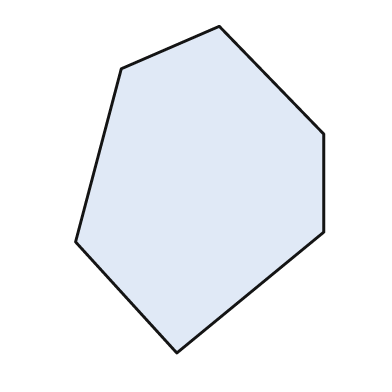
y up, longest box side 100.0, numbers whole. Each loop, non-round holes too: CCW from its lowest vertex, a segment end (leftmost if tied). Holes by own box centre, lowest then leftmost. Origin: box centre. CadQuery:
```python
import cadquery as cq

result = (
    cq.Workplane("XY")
    .moveTo(-7.0, -50.0)
    .lineTo(38.0, -13.0)
    .lineTo(38.0, 17.0)
    .lineTo(6.0, 50.0)
    .lineTo(-24.0, 37.0)
    .lineTo(-38.0, -16.0)
    .close()
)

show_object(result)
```